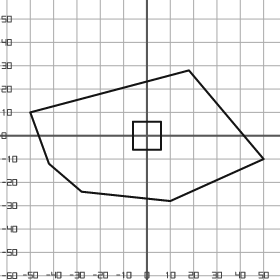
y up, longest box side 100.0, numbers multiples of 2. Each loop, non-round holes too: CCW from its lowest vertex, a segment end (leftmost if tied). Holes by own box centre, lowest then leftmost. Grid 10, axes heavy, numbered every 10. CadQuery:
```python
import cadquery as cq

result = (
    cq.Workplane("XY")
    .moveTo(10.0, -28.0)
    .lineTo(50.0, -10.0)
    .lineTo(18.0, 28.0)
    .lineTo(-50.0, 10.0)
    .lineTo(-42.0, -12.0)
    .lineTo(-28.0, -24.0)
    .close()
    .moveTo(-6.0, -6.0)
    .lineTo(6.0, -6.0)
    .lineTo(6.0, 6.0)
    .lineTo(-6.0, 6.0)
    .close()
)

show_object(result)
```